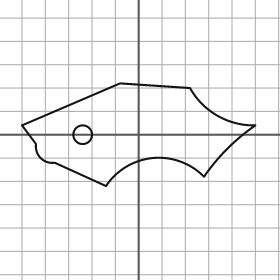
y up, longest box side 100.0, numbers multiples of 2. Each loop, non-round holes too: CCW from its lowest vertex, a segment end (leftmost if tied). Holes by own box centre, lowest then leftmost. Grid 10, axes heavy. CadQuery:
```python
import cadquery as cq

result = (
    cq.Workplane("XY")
    .moveTo(-14.0, -22.0)
    .threePointArc((6.0, -10.0), (28.0, -18.0))
    .threePointArc((38.0, -6.0), (50.0, 4.0))
    .threePointArc((34.0, 8.0), (22.0, 20.0))
    .lineTo(-8.0, 22.0)
    .lineTo(-50.0, 4.0)
    .lineTo(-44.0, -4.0)
    .threePointArc((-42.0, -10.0), (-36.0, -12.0))
    .close()
    .moveTo(-24.0, 0.0)
    .circle(4.0)
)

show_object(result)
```